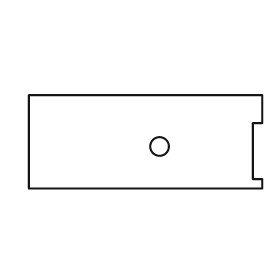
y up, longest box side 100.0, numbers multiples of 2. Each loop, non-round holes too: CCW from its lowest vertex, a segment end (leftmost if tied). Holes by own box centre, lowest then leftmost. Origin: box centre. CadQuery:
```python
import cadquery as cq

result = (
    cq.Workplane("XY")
    .moveTo(-50.0, -20.0)
    .lineTo(50.0, -20.0)
    .lineTo(50.0, -16.0)
    .lineTo(46.0, -16.0)
    .lineTo(46.0, 8.0)
    .lineTo(50.0, 8.0)
    .lineTo(50.0, 20.0)
    .lineTo(-50.0, 20.0)
    .close()
    .moveTo(6.0, -2.0)
    .circle(4.0)
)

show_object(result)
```